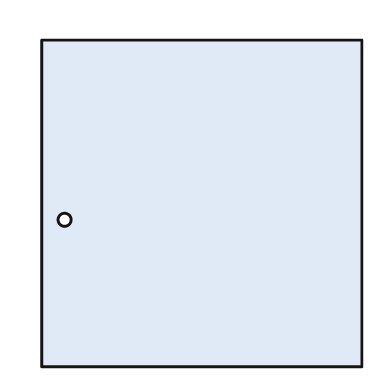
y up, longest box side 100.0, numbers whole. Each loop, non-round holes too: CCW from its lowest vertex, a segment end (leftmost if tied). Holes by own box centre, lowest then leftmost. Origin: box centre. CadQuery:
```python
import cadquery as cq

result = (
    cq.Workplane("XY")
    .moveTo(-49.0, -50.0)
    .lineTo(49.0, -50.0)
    .lineTo(49.0, 50.0)
    .lineTo(-49.0, 50.0)
    .close()
    .moveTo(-42.0, -5.0)
    .circle(2.0)
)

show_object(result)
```